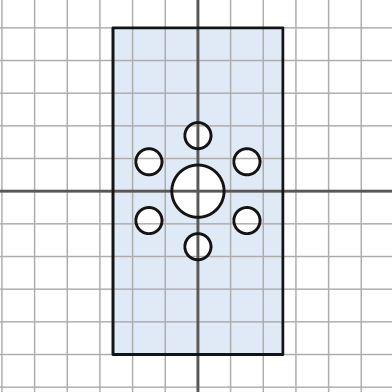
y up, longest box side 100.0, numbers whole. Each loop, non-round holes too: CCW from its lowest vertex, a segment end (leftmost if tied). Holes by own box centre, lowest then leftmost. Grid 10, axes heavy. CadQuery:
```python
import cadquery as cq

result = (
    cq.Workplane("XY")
    .moveTo(-26.0, -50.0)
    .lineTo(26.0, -50.0)
    .lineTo(26.0, 50.0)
    .lineTo(-26.0, 50.0)
    .close()
    .moveTo(0.0, -17.0)
    .circle(4.0)
    .moveTo(-15.0, -9.0)
    .circle(4.0)
    .moveTo(15.0, -9.0)
    .circle(4.0)
    .moveTo(0.0, 0.0)
    .circle(8.0)
    .moveTo(-15.0, 9.0)
    .circle(4.0)
    .moveTo(15.0, 9.0)
    .circle(4.0)
    .moveTo(0.0, 17.0)
    .circle(4.0)
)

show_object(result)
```